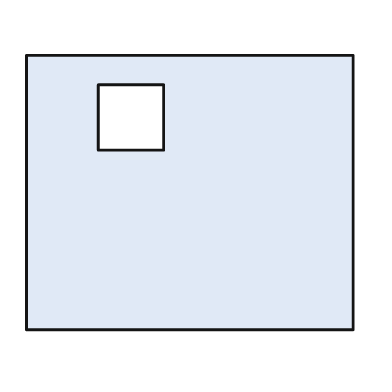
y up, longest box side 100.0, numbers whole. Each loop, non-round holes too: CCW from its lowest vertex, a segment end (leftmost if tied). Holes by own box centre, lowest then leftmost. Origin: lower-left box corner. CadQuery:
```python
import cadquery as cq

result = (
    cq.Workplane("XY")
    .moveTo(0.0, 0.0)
    .lineTo(100.0, 0.0)
    .lineTo(100.0, 84.0)
    .lineTo(0.0, 84.0)
    .close()
    .moveTo(22.0, 55.0)
    .lineTo(42.0, 55.0)
    .lineTo(42.0, 75.0)
    .lineTo(22.0, 75.0)
    .close()
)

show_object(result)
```